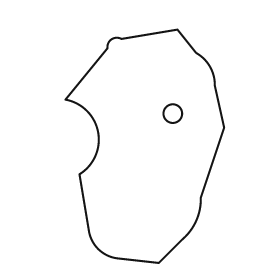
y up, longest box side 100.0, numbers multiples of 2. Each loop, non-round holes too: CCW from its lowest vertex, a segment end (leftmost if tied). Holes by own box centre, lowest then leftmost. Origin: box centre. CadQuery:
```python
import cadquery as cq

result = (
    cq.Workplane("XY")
    .moveTo(6.0, -50.0)
    .lineTo(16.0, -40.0)
    .threePointArc((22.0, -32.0), (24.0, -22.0))
    .lineTo(34.0, 8.0)
    .lineTo(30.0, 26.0)
    .threePointArc((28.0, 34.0), (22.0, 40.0))
    .lineTo(14.0, 50.0)
    .lineTo(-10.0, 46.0)
    .threePointArc((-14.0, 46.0), (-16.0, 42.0))
    .lineTo(-34.0, 20.0)
    .threePointArc((-20.0, 6.0), (-28.0, -12.0))
    .lineTo(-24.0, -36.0)
    .threePointArc((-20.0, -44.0), (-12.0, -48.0))
    .close()
    .moveTo(12.0, 14.0)
    .circle(4.0)
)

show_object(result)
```